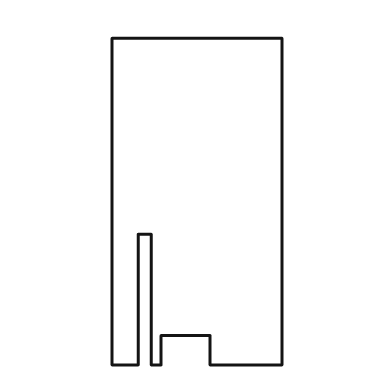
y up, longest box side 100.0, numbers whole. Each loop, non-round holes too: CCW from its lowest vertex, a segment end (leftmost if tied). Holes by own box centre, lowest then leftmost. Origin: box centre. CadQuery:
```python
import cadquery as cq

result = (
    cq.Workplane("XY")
    .moveTo(-26.0, -50.0)
    .lineTo(-18.0, -50.0)
    .lineTo(-18.0, -10.0)
    .lineTo(-14.0, -10.0)
    .lineTo(-14.0, -50.0)
    .lineTo(-11.0, -50.0)
    .lineTo(-11.0, -41.0)
    .lineTo(4.0, -41.0)
    .lineTo(4.0, -50.0)
    .lineTo(26.0, -50.0)
    .lineTo(26.0, 50.0)
    .lineTo(-26.0, 50.0)
    .close()
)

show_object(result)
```